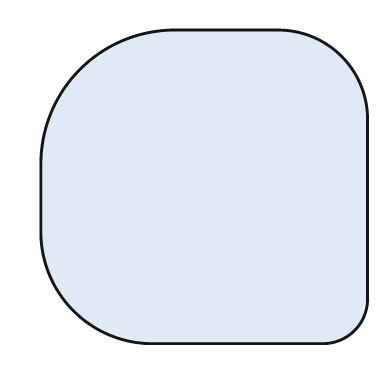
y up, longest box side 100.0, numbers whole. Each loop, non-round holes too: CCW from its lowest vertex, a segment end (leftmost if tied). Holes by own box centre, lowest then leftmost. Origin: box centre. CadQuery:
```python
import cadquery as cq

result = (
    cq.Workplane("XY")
    .moveTo(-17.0, -48.0)
    .lineTo(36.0, -48.0)
    .threePointArc((46.0, -44.0), (50.0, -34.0))
    .lineTo(50.0, 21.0)
    .threePointArc((42.0, 40.0), (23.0, 48.0))
    .lineTo(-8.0, 48.0)
    .threePointArc((-38.0, 36.0), (-50.0, 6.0))
    .lineTo(-50.0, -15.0)
    .threePointArc((-40.0, -38.0), (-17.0, -48.0))
    .close()
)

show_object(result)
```